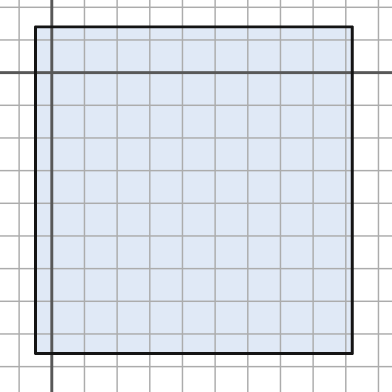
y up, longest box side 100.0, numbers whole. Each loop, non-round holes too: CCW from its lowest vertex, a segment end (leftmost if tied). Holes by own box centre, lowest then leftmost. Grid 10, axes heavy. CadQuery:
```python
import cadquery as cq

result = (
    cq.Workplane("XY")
    .moveTo(-5.0, -86.0)
    .lineTo(92.0, -86.0)
    .lineTo(92.0, 14.0)
    .lineTo(-5.0, 14.0)
    .close()
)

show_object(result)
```